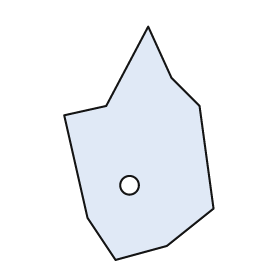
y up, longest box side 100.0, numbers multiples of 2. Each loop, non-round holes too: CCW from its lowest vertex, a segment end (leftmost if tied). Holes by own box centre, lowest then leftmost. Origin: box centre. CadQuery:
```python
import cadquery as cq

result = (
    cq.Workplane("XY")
    .moveTo(-10.0, -50.0)
    .lineTo(12.0, -44.0)
    .lineTo(32.0, -28.0)
    .lineTo(26.0, 16.0)
    .lineTo(14.0, 28.0)
    .lineTo(4.0, 50.0)
    .lineTo(-14.0, 16.0)
    .lineTo(-32.0, 12.0)
    .lineTo(-22.0, -32.0)
    .close()
    .moveTo(-4.0, -18.0)
    .circle(4.0)
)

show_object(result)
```